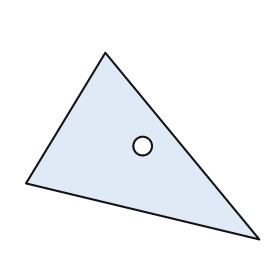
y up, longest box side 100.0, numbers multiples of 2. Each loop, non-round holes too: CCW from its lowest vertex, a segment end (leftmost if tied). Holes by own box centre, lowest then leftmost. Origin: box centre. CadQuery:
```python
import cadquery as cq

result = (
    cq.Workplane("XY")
    .moveTo(50.0, -40.0)
    .lineTo(-16.0, 40.0)
    .lineTo(-50.0, -16.0)
    .close()
    .moveTo(0.0, 0.0)
    .circle(4.0)
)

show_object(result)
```